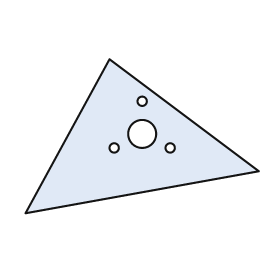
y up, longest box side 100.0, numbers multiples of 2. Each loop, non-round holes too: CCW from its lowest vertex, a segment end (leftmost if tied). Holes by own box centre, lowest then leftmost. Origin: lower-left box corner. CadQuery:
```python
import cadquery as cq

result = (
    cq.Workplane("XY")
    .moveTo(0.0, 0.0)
    .lineTo(100.0, 18.0)
    .lineTo(36.0, 66.0)
    .close()
    .moveTo(38.0, 28.0)
    .circle(2.0)
    .moveTo(62.0, 28.0)
    .circle(2.0)
    .moveTo(50.0, 34.0)
    .circle(6.0)
    .moveTo(50.0, 48.0)
    .circle(2.0)
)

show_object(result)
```